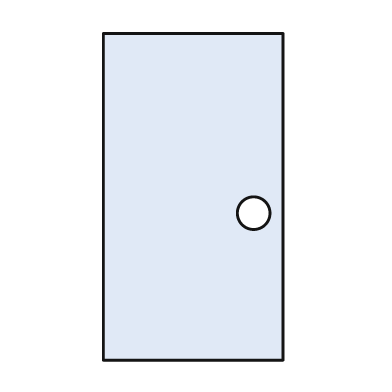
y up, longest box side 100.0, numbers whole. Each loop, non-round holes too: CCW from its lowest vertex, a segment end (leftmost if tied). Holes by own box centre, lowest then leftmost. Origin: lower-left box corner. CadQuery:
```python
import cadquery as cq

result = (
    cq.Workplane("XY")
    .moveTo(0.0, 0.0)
    .lineTo(55.0, 0.0)
    .lineTo(55.0, 100.0)
    .lineTo(0.0, 100.0)
    .close()
    .moveTo(46.0, 45.0)
    .circle(5.0)
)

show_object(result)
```